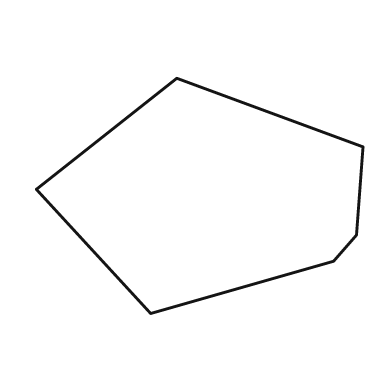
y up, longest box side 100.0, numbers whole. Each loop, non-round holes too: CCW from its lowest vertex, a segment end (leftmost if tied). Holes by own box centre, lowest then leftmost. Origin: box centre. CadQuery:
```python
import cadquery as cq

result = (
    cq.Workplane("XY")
    .moveTo(-15.0, -36.0)
    .lineTo(41.0, -20.0)
    .lineTo(48.0, -12.0)
    .lineTo(50.0, 15.0)
    .lineTo(-7.0, 36.0)
    .lineTo(-50.0, 2.0)
    .close()
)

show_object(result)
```